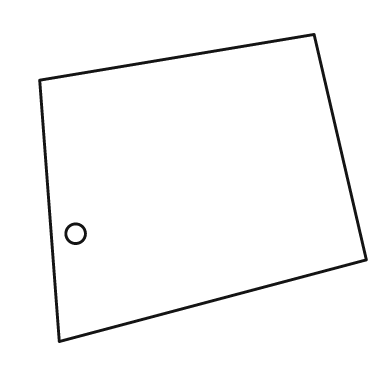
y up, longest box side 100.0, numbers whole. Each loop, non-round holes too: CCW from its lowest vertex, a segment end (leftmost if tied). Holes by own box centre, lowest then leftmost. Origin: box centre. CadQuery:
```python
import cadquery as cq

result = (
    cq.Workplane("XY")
    .moveTo(-44.0, -47.0)
    .lineTo(50.0, -22.0)
    .lineTo(34.0, 47.0)
    .lineTo(-50.0, 33.0)
    .close()
    .moveTo(-39.0, -14.0)
    .circle(3.0)
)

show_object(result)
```